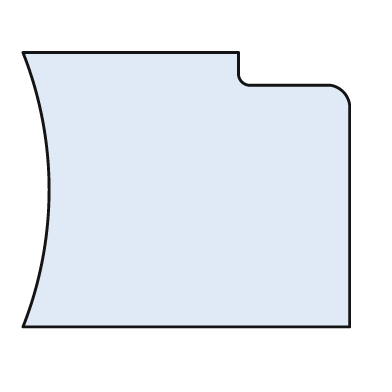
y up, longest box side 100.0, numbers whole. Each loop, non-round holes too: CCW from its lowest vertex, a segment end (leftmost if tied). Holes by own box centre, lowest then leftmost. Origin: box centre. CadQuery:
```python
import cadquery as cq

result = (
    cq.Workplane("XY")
    .moveTo(-50.0, -42.0)
    .lineTo(50.0, -42.0)
    .lineTo(50.0, 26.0)
    .threePointArc((48.0, 30.0), (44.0, 32.0))
    .lineTo(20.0, 32.0)
    .threePointArc((17.0, 33.0), (16.0, 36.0))
    .lineTo(16.0, 42.0)
    .lineTo(-50.0, 42.0)
    .threePointArc((-42.0, 0.0), (-50.0, -42.0))
    .close()
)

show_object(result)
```